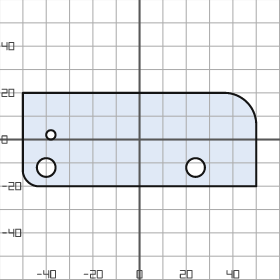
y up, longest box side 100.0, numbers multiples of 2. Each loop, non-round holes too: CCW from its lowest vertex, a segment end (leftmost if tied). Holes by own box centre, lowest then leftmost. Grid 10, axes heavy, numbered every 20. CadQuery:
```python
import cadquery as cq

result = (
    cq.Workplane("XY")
    .moveTo(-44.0, -20.0)
    .lineTo(50.0, -20.0)
    .lineTo(50.0, 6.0)
    .threePointArc((46.0, 16.0), (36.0, 20.0))
    .lineTo(-50.0, 20.0)
    .lineTo(-50.0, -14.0)
    .threePointArc((-48.0, -18.0), (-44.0, -20.0))
    .close()
    .moveTo(-40.0, -12.0)
    .circle(4.0)
    .moveTo(24.0, -12.0)
    .circle(4.0)
    .moveTo(-38.0, 2.0)
    .circle(2.0)
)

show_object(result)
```